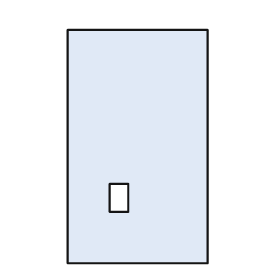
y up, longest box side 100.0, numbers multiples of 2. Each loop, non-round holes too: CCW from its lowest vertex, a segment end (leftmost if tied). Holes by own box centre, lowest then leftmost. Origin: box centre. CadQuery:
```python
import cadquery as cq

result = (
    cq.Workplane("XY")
    .moveTo(-30.0, -50.0)
    .lineTo(30.0, -50.0)
    .lineTo(30.0, 50.0)
    .lineTo(-30.0, 50.0)
    .close()
    .moveTo(-12.0, -28.0)
    .lineTo(-4.0, -28.0)
    .lineTo(-4.0, -16.0)
    .lineTo(-12.0, -16.0)
    .close()
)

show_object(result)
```